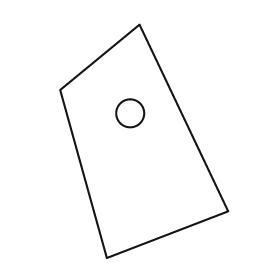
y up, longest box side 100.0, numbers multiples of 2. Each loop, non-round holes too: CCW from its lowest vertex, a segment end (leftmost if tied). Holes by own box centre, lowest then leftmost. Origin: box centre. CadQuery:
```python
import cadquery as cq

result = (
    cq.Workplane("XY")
    .moveTo(-16.0, -50.0)
    .lineTo(36.0, -30.0)
    .lineTo(-2.0, 50.0)
    .lineTo(-36.0, 22.0)
    .close()
    .moveTo(-6.0, 12.0)
    .circle(6.0)
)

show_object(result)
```